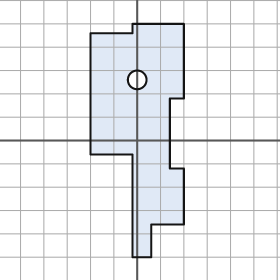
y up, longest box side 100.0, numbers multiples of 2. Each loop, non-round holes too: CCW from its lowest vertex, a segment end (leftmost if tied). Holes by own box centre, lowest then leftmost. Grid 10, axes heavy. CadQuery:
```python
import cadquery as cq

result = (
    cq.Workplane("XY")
    .moveTo(-2.0, -50.0)
    .lineTo(6.0, -50.0)
    .lineTo(6.0, -36.0)
    .lineTo(20.0, -36.0)
    .lineTo(20.0, -12.0)
    .lineTo(14.0, -12.0)
    .lineTo(14.0, 18.0)
    .lineTo(20.0, 18.0)
    .lineTo(20.0, 50.0)
    .lineTo(-2.0, 50.0)
    .lineTo(-2.0, 46.0)
    .lineTo(-20.0, 46.0)
    .lineTo(-20.0, -6.0)
    .lineTo(-2.0, -6.0)
    .close()
    .moveTo(0.0, 26.0)
    .circle(4.0)
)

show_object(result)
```